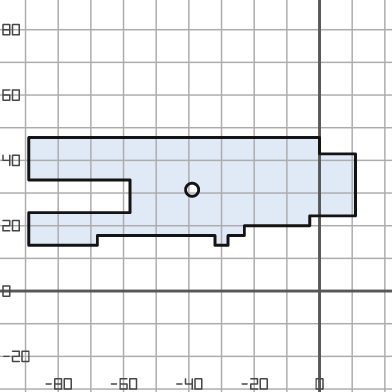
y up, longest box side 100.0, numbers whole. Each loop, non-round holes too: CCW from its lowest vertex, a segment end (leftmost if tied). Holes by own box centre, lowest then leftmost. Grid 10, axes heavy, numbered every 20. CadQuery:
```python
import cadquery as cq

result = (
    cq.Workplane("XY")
    .moveTo(-89.0, 14.0)
    .lineTo(-68.0, 14.0)
    .lineTo(-68.0, 17.0)
    .lineTo(-32.0, 17.0)
    .lineTo(-32.0, 14.0)
    .lineTo(-28.0, 14.0)
    .lineTo(-28.0, 17.0)
    .lineTo(-23.0, 17.0)
    .lineTo(-23.0, 20.0)
    .lineTo(-3.0, 20.0)
    .lineTo(-3.0, 23.0)
    .lineTo(11.0, 23.0)
    .lineTo(11.0, 42.0)
    .lineTo(0.0, 42.0)
    .lineTo(0.0, 47.0)
    .lineTo(-89.0, 47.0)
    .lineTo(-89.0, 34.0)
    .lineTo(-58.0, 34.0)
    .lineTo(-58.0, 24.0)
    .lineTo(-89.0, 24.0)
    .close()
    .moveTo(-39.0, 31.0)
    .circle(2.0)
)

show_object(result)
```